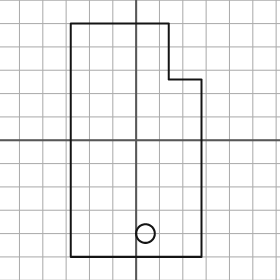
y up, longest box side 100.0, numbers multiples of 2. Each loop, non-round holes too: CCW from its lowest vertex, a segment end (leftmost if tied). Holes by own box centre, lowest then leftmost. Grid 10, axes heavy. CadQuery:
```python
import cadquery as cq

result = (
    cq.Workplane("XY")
    .moveTo(-28.0, -50.0)
    .lineTo(28.0, -50.0)
    .lineTo(28.0, 26.0)
    .lineTo(14.0, 26.0)
    .lineTo(14.0, 50.0)
    .lineTo(-28.0, 50.0)
    .close()
    .moveTo(4.0, -40.0)
    .circle(4.0)
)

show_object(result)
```